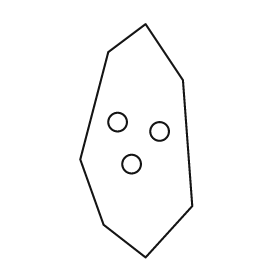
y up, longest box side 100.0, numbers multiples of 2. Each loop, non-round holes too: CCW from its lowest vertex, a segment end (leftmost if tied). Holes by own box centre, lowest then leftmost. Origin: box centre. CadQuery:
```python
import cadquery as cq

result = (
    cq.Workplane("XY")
    .moveTo(4.0, -50.0)
    .lineTo(24.0, -28.0)
    .lineTo(20.0, 26.0)
    .lineTo(4.0, 50.0)
    .lineTo(-12.0, 38.0)
    .lineTo(-24.0, -8.0)
    .lineTo(-14.0, -36.0)
    .close()
    .moveTo(-2.0, -10.0)
    .circle(4.0)
    .moveTo(10.0, 4.0)
    .circle(4.0)
    .moveTo(-8.0, 8.0)
    .circle(4.0)
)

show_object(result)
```